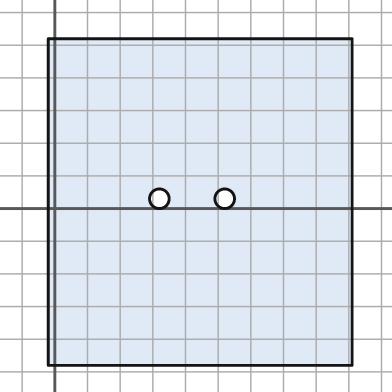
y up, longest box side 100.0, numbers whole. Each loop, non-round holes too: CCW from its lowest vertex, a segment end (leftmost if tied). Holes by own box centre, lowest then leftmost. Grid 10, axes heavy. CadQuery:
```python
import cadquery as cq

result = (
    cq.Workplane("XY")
    .moveTo(-2.0, -48.0)
    .lineTo(91.0, -48.0)
    .lineTo(91.0, 52.0)
    .lineTo(-2.0, 52.0)
    .close()
    .moveTo(32.0, 3.0)
    .circle(3.0)
    .moveTo(52.0, 3.0)
    .circle(3.0)
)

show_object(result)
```